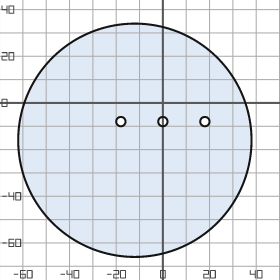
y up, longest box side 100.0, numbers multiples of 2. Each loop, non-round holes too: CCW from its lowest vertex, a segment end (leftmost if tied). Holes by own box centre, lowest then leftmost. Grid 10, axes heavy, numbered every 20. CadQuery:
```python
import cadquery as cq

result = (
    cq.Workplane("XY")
    .moveTo(-12.0, -16.0)
    .circle(50.0)
    .moveTo(-18.0, -8.0)
    .circle(2.0)
    .moveTo(0.0, -8.0)
    .circle(2.0)
    .moveTo(18.0, -8.0)
    .circle(2.0)
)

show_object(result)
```